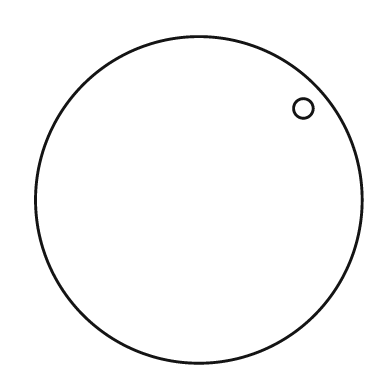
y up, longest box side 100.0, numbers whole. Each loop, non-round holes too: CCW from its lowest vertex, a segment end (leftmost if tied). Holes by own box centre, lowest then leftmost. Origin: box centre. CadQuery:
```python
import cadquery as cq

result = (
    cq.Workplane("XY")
    .moveTo(0.0, 0.0)
    .circle(50.0)
    .moveTo(32.0, 28.0)
    .circle(3.0)
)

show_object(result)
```